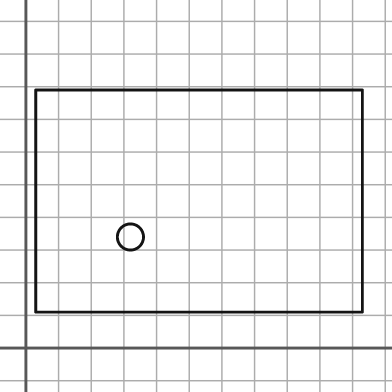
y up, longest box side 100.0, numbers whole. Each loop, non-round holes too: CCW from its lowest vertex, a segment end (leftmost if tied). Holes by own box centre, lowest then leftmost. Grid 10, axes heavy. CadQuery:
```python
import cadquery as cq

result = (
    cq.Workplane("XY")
    .moveTo(3.0, 11.0)
    .lineTo(103.0, 11.0)
    .lineTo(103.0, 79.0)
    .lineTo(3.0, 79.0)
    .close()
    .moveTo(32.0, 34.0)
    .circle(4.0)
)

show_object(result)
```